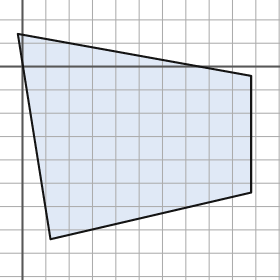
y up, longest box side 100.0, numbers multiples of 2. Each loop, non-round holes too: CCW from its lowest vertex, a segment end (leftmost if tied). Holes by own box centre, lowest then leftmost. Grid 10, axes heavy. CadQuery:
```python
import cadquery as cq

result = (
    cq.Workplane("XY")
    .moveTo(12.0, -74.0)
    .lineTo(98.0, -54.0)
    .lineTo(98.0, -4.0)
    .lineTo(-2.0, 14.0)
    .close()
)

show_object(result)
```